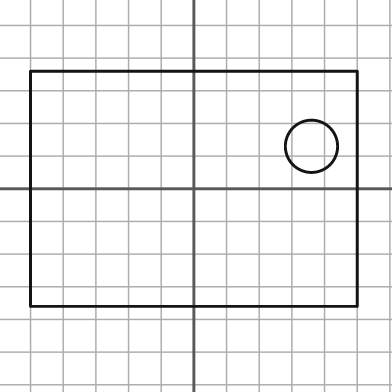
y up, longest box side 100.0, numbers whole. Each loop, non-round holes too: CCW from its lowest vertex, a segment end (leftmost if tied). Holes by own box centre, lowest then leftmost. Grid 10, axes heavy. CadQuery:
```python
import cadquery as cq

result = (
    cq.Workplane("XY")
    .moveTo(-50.0, -36.0)
    .lineTo(50.0, -36.0)
    .lineTo(50.0, 36.0)
    .lineTo(-50.0, 36.0)
    .close()
    .moveTo(36.0, 13.0)
    .circle(8.0)
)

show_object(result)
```